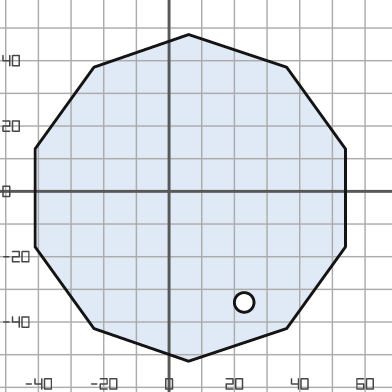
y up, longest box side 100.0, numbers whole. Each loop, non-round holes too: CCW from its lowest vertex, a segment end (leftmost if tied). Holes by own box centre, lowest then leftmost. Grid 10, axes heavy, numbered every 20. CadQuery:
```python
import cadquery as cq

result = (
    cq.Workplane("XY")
    .moveTo(6.0, -52.0)
    .lineTo(36.0, -42.0)
    .lineTo(54.0, -17.0)
    .lineTo(54.0, 13.0)
    .lineTo(36.0, 38.0)
    .lineTo(6.0, 48.0)
    .lineTo(-23.0, 38.0)
    .lineTo(-41.0, 13.0)
    .lineTo(-41.0, -17.0)
    .lineTo(-23.0, -42.0)
    .close()
    .moveTo(23.0, -34.0)
    .circle(3.0)
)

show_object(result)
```